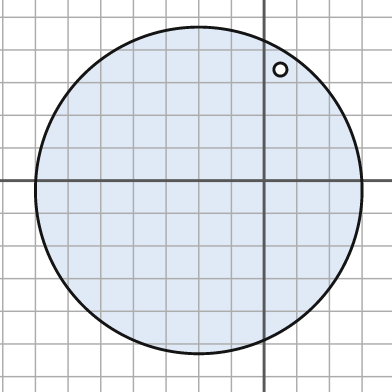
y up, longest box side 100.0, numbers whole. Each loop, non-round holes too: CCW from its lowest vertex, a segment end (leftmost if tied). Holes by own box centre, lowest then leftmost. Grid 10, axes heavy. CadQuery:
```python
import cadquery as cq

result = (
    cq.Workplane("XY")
    .moveTo(-20.0, -3.0)
    .circle(50.0)
    .moveTo(5.0, 34.0)
    .circle(2.0)
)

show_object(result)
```